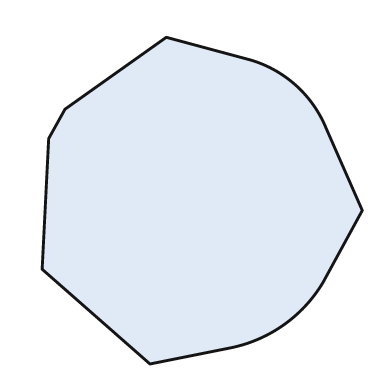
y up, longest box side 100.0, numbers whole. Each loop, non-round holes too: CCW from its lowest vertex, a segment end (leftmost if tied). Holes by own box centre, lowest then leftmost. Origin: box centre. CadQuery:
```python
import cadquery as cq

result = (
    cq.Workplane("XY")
    .moveTo(-16.0, -50.0)
    .lineTo(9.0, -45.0)
    .threePointArc((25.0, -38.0), (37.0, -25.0))
    .lineTo(49.0, -3.0)
    .lineTo(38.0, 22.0)
    .threePointArc((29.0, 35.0), (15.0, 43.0))
    .lineTo(-11.0, 50.0)
    .lineTo(-42.0, 28.0)
    .lineTo(-47.0, 19.0)
    .lineTo(-49.0, -21.0)
    .close()
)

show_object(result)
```